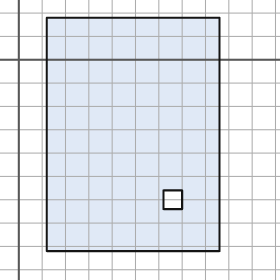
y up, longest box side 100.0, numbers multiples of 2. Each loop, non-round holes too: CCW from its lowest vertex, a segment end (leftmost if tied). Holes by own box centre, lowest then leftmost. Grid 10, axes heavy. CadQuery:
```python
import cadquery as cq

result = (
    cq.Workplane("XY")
    .moveTo(12.0, -82.0)
    .lineTo(86.0, -82.0)
    .lineTo(86.0, 18.0)
    .lineTo(12.0, 18.0)
    .close()
    .moveTo(62.0, -64.0)
    .lineTo(70.0, -64.0)
    .lineTo(70.0, -56.0)
    .lineTo(62.0, -56.0)
    .close()
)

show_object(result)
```